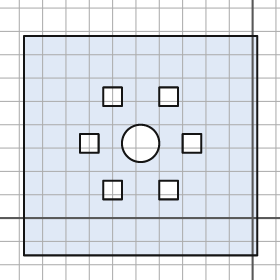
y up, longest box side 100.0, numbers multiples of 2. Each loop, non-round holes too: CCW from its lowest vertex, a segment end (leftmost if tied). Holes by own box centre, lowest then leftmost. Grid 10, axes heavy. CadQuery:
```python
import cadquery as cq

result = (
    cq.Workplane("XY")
    .moveTo(-98.0, -16.0)
    .lineTo(2.0, -16.0)
    .lineTo(2.0, 78.0)
    .lineTo(-98.0, 78.0)
    .close()
    .moveTo(-64.0, 8.0)
    .lineTo(-56.0, 8.0)
    .lineTo(-56.0, 16.0)
    .lineTo(-64.0, 16.0)
    .close()
    .moveTo(-40.0, 8.0)
    .lineTo(-32.0, 8.0)
    .lineTo(-32.0, 16.0)
    .lineTo(-40.0, 16.0)
    .close()
    .moveTo(-74.0, 28.0)
    .lineTo(-66.0, 28.0)
    .lineTo(-66.0, 36.0)
    .lineTo(-74.0, 36.0)
    .close()
    .moveTo(-48.0, 32.0)
    .circle(8.0)
    .moveTo(-30.0, 28.0)
    .lineTo(-22.0, 28.0)
    .lineTo(-22.0, 36.0)
    .lineTo(-30.0, 36.0)
    .close()
    .moveTo(-64.0, 48.0)
    .lineTo(-56.0, 48.0)
    .lineTo(-56.0, 56.0)
    .lineTo(-64.0, 56.0)
    .close()
    .moveTo(-40.0, 48.0)
    .lineTo(-32.0, 48.0)
    .lineTo(-32.0, 56.0)
    .lineTo(-40.0, 56.0)
    .close()
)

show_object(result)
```